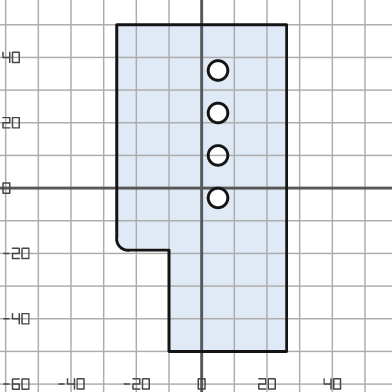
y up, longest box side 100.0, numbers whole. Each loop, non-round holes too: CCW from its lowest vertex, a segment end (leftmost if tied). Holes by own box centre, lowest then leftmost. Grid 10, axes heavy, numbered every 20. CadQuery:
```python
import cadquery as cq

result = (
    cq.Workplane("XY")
    .moveTo(-10.0, -50.0)
    .lineTo(26.0, -50.0)
    .lineTo(26.0, 50.0)
    .lineTo(-26.0, 50.0)
    .lineTo(-26.0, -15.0)
    .threePointArc((-25.0, -18.0), (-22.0, -19.0))
    .lineTo(-10.0, -19.0)
    .close()
    .moveTo(5.0, -3.0)
    .circle(3.0)
    .moveTo(5.0, 10.0)
    .circle(3.0)
    .moveTo(5.0, 23.0)
    .circle(3.0)
    .moveTo(5.0, 36.0)
    .circle(3.0)
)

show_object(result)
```